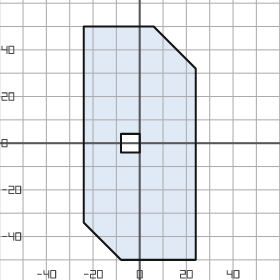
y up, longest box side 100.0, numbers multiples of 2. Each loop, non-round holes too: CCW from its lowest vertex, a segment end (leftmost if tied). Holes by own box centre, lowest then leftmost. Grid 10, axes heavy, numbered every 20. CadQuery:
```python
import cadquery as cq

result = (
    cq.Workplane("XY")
    .moveTo(-8.0, -50.0)
    .lineTo(24.0, -50.0)
    .lineTo(24.0, 32.0)
    .lineTo(6.0, 50.0)
    .lineTo(-24.0, 50.0)
    .lineTo(-24.0, -34.0)
    .close()
    .moveTo(-8.0, -4.0)
    .lineTo(0.0, -4.0)
    .lineTo(0.0, 4.0)
    .lineTo(-8.0, 4.0)
    .close()
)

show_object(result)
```